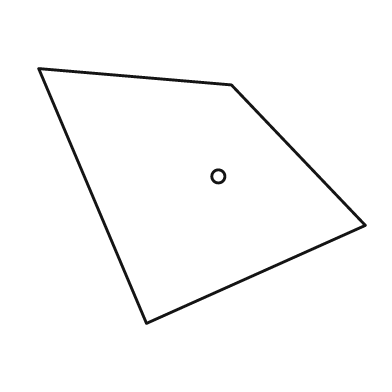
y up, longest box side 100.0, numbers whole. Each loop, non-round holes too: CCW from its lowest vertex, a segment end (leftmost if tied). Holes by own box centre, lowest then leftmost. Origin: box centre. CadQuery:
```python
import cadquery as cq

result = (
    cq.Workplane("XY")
    .moveTo(-17.0, -39.0)
    .lineTo(50.0, -9.0)
    .lineTo(9.0, 34.0)
    .lineTo(-50.0, 39.0)
    .close()
    .moveTo(5.0, 6.0)
    .circle(2.0)
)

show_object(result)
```